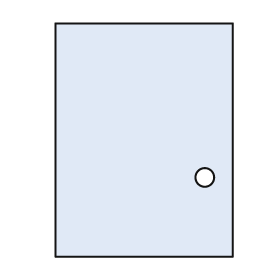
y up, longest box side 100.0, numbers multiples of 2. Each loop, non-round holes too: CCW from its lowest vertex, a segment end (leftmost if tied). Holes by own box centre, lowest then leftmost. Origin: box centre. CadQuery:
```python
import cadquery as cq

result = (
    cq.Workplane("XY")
    .moveTo(-38.0, -50.0)
    .lineTo(38.0, -50.0)
    .lineTo(38.0, 50.0)
    .lineTo(-38.0, 50.0)
    .close()
    .moveTo(26.0, -16.0)
    .circle(4.0)
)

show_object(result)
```